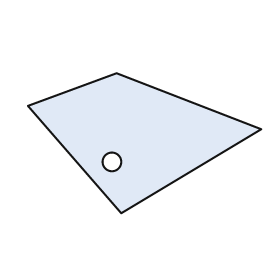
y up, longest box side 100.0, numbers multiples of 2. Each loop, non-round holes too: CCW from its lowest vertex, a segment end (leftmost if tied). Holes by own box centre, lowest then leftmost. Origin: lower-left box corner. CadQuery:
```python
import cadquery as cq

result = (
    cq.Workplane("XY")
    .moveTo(40.0, 0.0)
    .lineTo(100.0, 36.0)
    .lineTo(38.0, 60.0)
    .lineTo(0.0, 46.0)
    .close()
    .moveTo(36.0, 22.0)
    .circle(4.0)
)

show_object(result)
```